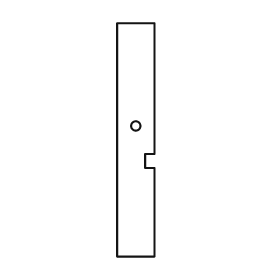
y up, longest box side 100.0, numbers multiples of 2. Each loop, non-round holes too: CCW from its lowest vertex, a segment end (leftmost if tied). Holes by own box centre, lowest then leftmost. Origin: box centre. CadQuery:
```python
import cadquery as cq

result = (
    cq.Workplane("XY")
    .moveTo(-8.0, -50.0)
    .lineTo(8.0, -50.0)
    .lineTo(8.0, -12.0)
    .lineTo(4.0, -12.0)
    .lineTo(4.0, -6.0)
    .lineTo(8.0, -6.0)
    .lineTo(8.0, 50.0)
    .lineTo(-8.0, 50.0)
    .close()
    .moveTo(0.0, 6.0)
    .circle(2.0)
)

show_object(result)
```